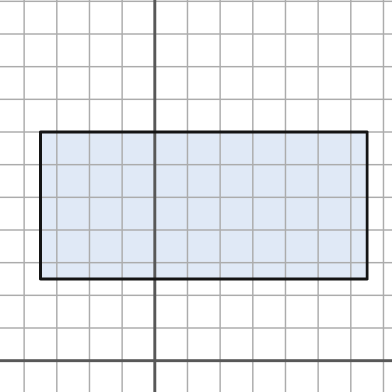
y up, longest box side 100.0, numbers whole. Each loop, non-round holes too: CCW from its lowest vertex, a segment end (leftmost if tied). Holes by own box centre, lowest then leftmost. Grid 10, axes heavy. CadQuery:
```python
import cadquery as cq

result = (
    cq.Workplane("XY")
    .moveTo(-35.0, 25.0)
    .lineTo(65.0, 25.0)
    .lineTo(65.0, 70.0)
    .lineTo(-35.0, 70.0)
    .close()
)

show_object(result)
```